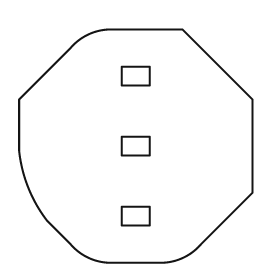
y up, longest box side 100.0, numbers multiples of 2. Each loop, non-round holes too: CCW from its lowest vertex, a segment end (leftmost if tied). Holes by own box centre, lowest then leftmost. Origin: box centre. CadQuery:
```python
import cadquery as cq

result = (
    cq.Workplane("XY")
    .moveTo(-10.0, -50.0)
    .lineTo(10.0, -50.0)
    .threePointArc((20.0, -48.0), (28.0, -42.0))
    .lineTo(50.0, -20.0)
    .lineTo(50.0, 20.0)
    .lineTo(20.0, 50.0)
    .lineTo(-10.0, 50.0)
    .threePointArc((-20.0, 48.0), (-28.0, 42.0))
    .lineTo(-50.0, 20.0)
    .lineTo(-50.0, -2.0)
    .threePointArc((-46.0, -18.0), (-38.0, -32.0))
    .lineTo(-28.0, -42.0)
    .threePointArc((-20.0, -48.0), (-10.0, -50.0))
    .close()
    .moveTo(-6.0, -34.0)
    .lineTo(6.0, -34.0)
    .lineTo(6.0, -26.0)
    .lineTo(-6.0, -26.0)
    .close()
    .moveTo(-6.0, -4.0)
    .lineTo(6.0, -4.0)
    .lineTo(6.0, 4.0)
    .lineTo(-6.0, 4.0)
    .close()
    .moveTo(-6.0, 26.0)
    .lineTo(6.0, 26.0)
    .lineTo(6.0, 34.0)
    .lineTo(-6.0, 34.0)
    .close()
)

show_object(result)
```